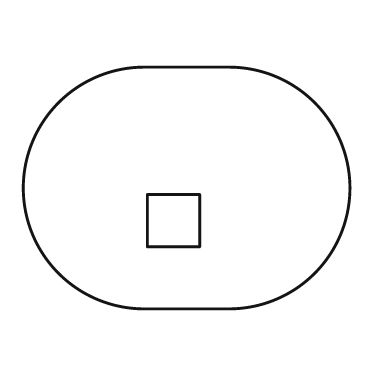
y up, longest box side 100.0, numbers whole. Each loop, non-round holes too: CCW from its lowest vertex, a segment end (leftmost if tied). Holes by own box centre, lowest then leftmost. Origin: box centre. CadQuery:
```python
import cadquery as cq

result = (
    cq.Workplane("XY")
    .moveTo(-13.0, -37.0)
    .lineTo(13.0, -37.0)
    .threePointArc((50.0, 0.0), (13.0, 37.0))
    .lineTo(-13.0, 37.0)
    .threePointArc((-50.0, 0.0), (-13.0, -37.0))
    .close()
    .moveTo(-12.0, -18.0)
    .lineTo(4.0, -18.0)
    .lineTo(4.0, -2.0)
    .lineTo(-12.0, -2.0)
    .close()
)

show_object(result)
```